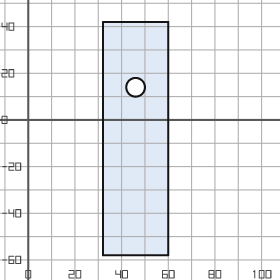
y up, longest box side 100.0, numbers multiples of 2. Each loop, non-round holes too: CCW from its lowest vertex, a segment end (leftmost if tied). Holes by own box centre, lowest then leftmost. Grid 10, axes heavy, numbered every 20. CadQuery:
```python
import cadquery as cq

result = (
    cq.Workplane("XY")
    .moveTo(32.0, -58.0)
    .lineTo(60.0, -58.0)
    .lineTo(60.0, 42.0)
    .lineTo(32.0, 42.0)
    .close()
    .moveTo(46.0, 14.0)
    .circle(4.0)
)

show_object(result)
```